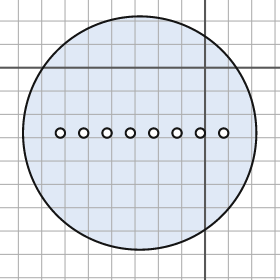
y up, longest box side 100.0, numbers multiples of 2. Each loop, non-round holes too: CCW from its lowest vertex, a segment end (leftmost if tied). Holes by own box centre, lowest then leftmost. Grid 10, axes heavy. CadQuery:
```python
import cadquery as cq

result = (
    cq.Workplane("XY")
    .moveTo(-28.0, -28.0)
    .circle(50.0)
    .moveTo(-62.0, -28.0)
    .circle(2.0)
    .moveTo(-52.0, -28.0)
    .circle(2.0)
    .moveTo(-42.0, -28.0)
    .circle(2.0)
    .moveTo(-32.0, -28.0)
    .circle(2.0)
    .moveTo(-22.0, -28.0)
    .circle(2.0)
    .moveTo(-12.0, -28.0)
    .circle(2.0)
    .moveTo(-2.0, -28.0)
    .circle(2.0)
    .moveTo(8.0, -28.0)
    .circle(2.0)
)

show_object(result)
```